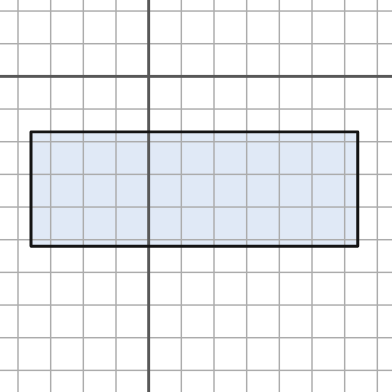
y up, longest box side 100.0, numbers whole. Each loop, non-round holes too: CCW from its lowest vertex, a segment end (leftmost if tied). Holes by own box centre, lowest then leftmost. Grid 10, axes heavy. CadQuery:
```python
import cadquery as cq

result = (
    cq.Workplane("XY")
    .moveTo(-36.0, -52.0)
    .lineTo(64.0, -52.0)
    .lineTo(64.0, -17.0)
    .lineTo(-36.0, -17.0)
    .close()
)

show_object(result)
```